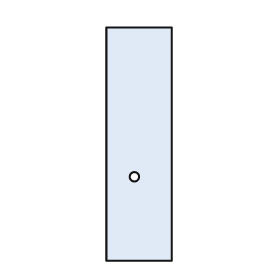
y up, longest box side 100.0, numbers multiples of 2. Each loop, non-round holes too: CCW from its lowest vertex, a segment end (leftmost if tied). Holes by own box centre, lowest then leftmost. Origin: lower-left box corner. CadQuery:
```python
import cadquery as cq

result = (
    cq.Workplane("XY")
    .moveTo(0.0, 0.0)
    .lineTo(28.0, 0.0)
    .lineTo(28.0, 100.0)
    .lineTo(0.0, 100.0)
    .close()
    .moveTo(12.0, 36.0)
    .circle(2.0)
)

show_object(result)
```